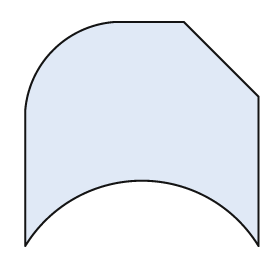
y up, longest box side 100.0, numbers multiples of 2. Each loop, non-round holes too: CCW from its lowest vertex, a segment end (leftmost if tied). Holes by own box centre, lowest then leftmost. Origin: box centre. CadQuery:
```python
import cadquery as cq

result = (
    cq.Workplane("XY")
    .moveTo(-50.0, -48.0)
    .threePointArc((0.0, -20.0), (50.0, -48.0))
    .lineTo(50.0, 16.0)
    .lineTo(18.0, 48.0)
    .lineTo(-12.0, 48.0)
    .threePointArc((-38.0, 36.0), (-50.0, 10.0))
    .close()
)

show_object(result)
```